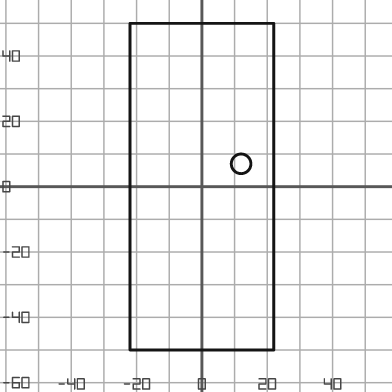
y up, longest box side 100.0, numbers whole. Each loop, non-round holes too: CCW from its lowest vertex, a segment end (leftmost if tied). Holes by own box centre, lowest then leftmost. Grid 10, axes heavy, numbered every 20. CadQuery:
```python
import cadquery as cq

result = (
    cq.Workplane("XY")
    .moveTo(-22.0, -50.0)
    .lineTo(22.0, -50.0)
    .lineTo(22.0, 50.0)
    .lineTo(-22.0, 50.0)
    .close()
    .moveTo(12.0, 7.0)
    .circle(3.0)
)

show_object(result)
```